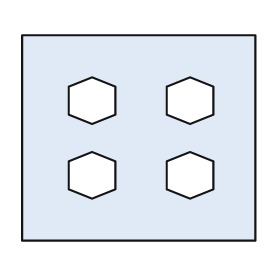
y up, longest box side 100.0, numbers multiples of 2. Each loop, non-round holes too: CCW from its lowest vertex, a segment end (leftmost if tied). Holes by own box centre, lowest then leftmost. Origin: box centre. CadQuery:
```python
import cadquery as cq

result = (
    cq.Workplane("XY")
    .moveTo(-50.0, -44.0)
    .lineTo(50.0, -44.0)
    .lineTo(50.0, 44.0)
    .lineTo(-50.0, 44.0)
    .close()
    .moveTo(-20.0, -26.0)
    .lineTo(-10.0, -22.0)
    .lineTo(-10.0, -10.0)
    .lineTo(-20.0, -6.0)
    .lineTo(-30.0, -10.0)
    .lineTo(-30.0, -22.0)
    .close()
    .moveTo(22.0, -26.0)
    .lineTo(32.0, -22.0)
    .lineTo(32.0, -10.0)
    .lineTo(22.0, -6.0)
    .lineTo(12.0, -10.0)
    .lineTo(12.0, -22.0)
    .close()
    .moveTo(-20.0, 6.0)
    .lineTo(-10.0, 10.0)
    .lineTo(-10.0, 22.0)
    .lineTo(-20.0, 26.0)
    .lineTo(-30.0, 22.0)
    .lineTo(-30.0, 10.0)
    .close()
    .moveTo(22.0, 6.0)
    .lineTo(32.0, 10.0)
    .lineTo(32.0, 22.0)
    .lineTo(22.0, 26.0)
    .lineTo(12.0, 22.0)
    .lineTo(12.0, 10.0)
    .close()
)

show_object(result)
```